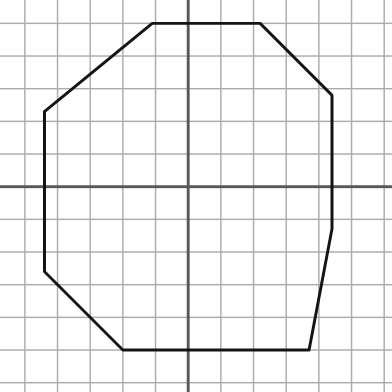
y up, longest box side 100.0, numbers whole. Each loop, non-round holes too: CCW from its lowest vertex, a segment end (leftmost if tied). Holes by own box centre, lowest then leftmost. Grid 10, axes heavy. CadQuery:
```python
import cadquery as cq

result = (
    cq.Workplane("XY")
    .moveTo(-20.0, -50.0)
    .lineTo(37.0, -50.0)
    .lineTo(44.0, -13.0)
    .lineTo(44.0, 28.0)
    .lineTo(22.0, 50.0)
    .lineTo(-11.0, 50.0)
    .lineTo(-44.0, 23.0)
    .lineTo(-44.0, -26.0)
    .close()
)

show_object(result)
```